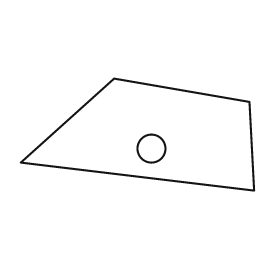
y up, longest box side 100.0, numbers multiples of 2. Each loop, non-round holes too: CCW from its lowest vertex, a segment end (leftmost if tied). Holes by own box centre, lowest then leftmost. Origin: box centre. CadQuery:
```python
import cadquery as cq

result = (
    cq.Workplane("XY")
    .moveTo(50.0, -24.0)
    .lineTo(48.0, 14.0)
    .lineTo(-10.0, 24.0)
    .lineTo(-50.0, -12.0)
    .close()
    .moveTo(6.0, -6.0)
    .circle(6.0)
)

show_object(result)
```